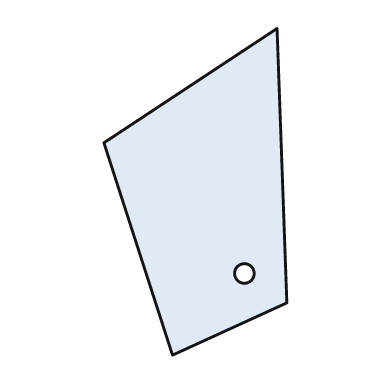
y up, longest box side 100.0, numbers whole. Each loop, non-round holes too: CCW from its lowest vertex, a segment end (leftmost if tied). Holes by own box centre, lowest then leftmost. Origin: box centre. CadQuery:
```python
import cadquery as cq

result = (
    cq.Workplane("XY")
    .moveTo(-7.0, -50.0)
    .lineTo(28.0, -34.0)
    .lineTo(25.0, 50.0)
    .lineTo(-28.0, 15.0)
    .close()
    .moveTo(15.0, -25.0)
    .circle(3.0)
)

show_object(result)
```